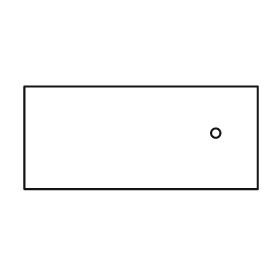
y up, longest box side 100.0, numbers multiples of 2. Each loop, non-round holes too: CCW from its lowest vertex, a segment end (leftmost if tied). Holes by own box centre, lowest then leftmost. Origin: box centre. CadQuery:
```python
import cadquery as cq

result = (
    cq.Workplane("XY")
    .moveTo(-50.0, -22.0)
    .lineTo(50.0, -22.0)
    .lineTo(50.0, 22.0)
    .lineTo(-50.0, 22.0)
    .close()
    .moveTo(32.0, 2.0)
    .circle(2.0)
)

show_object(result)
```